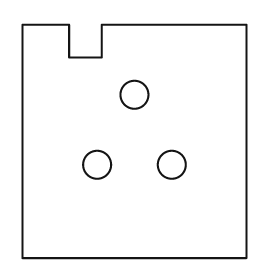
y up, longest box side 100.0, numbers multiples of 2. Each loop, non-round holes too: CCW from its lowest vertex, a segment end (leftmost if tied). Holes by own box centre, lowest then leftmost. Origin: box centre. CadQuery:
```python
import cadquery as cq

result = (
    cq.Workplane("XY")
    .moveTo(-48.0, -50.0)
    .lineTo(48.0, -50.0)
    .lineTo(48.0, 50.0)
    .lineTo(-14.0, 50.0)
    .lineTo(-14.0, 36.0)
    .lineTo(-28.0, 36.0)
    .lineTo(-28.0, 50.0)
    .lineTo(-48.0, 50.0)
    .close()
    .moveTo(-16.0, -10.0)
    .circle(6.0)
    .moveTo(16.0, -10.0)
    .circle(6.0)
    .moveTo(0.0, 20.0)
    .circle(6.0)
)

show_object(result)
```